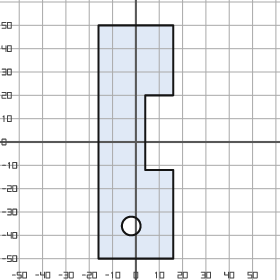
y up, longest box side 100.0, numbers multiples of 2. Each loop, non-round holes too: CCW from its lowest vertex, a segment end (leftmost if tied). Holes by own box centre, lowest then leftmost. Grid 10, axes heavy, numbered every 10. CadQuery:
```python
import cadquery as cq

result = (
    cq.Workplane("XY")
    .moveTo(-16.0, -50.0)
    .lineTo(16.0, -50.0)
    .lineTo(16.0, -12.0)
    .lineTo(4.0, -12.0)
    .lineTo(4.0, 20.0)
    .lineTo(16.0, 20.0)
    .lineTo(16.0, 50.0)
    .lineTo(-16.0, 50.0)
    .close()
    .moveTo(-2.0, -36.0)
    .circle(4.0)
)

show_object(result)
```